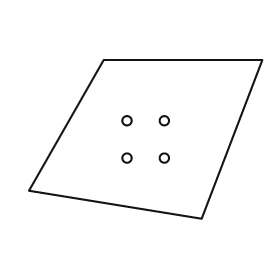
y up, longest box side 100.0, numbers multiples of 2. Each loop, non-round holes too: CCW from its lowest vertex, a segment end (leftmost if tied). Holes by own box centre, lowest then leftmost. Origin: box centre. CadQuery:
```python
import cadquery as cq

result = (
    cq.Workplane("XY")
    .moveTo(24.0, -34.0)
    .lineTo(50.0, 34.0)
    .lineTo(-18.0, 34.0)
    .lineTo(-50.0, -22.0)
    .close()
    .moveTo(-8.0, -8.0)
    .circle(2.0)
    .moveTo(8.0, -8.0)
    .circle(2.0)
    .moveTo(-8.0, 8.0)
    .circle(2.0)
    .moveTo(8.0, 8.0)
    .circle(2.0)
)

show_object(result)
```